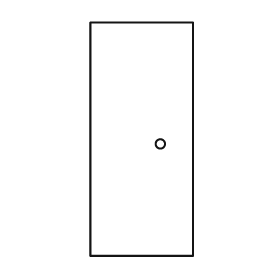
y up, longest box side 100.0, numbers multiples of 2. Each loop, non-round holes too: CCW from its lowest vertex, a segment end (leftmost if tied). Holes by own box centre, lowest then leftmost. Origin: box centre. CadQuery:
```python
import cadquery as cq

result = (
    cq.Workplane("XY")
    .moveTo(-22.0, -50.0)
    .lineTo(22.0, -50.0)
    .lineTo(22.0, 50.0)
    .lineTo(-22.0, 50.0)
    .close()
    .moveTo(8.0, -2.0)
    .circle(2.0)
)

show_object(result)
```